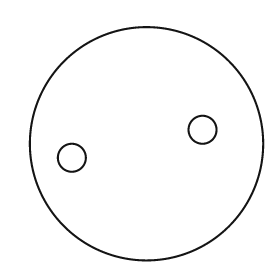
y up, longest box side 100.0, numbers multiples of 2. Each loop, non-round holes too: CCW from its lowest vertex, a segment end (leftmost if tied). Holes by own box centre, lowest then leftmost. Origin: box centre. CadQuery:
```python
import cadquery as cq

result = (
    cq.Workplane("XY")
    .moveTo(0.0, 0.0)
    .circle(50.0)
    .moveTo(-32.0, -6.0)
    .circle(6.0)
    .moveTo(24.0, 6.0)
    .circle(6.0)
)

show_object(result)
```